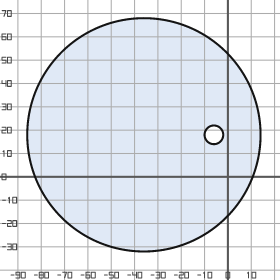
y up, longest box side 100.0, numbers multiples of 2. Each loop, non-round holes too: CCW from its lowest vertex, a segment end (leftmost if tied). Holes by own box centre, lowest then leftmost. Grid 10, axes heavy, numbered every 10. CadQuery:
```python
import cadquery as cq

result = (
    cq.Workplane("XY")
    .moveTo(-36.0, 18.0)
    .circle(50.0)
    .moveTo(-6.0, 18.0)
    .circle(4.0)
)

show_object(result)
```